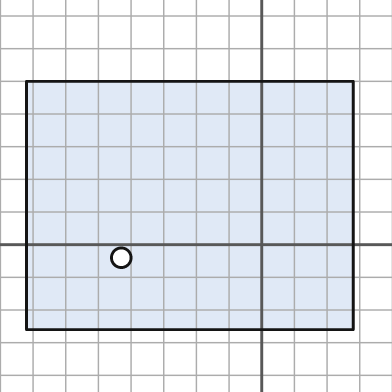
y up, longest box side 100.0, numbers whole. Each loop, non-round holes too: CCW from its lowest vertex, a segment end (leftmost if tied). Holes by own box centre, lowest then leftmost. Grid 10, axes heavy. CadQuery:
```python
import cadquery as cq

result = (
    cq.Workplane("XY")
    .moveTo(-72.0, -26.0)
    .lineTo(28.0, -26.0)
    .lineTo(28.0, 50.0)
    .lineTo(-72.0, 50.0)
    .close()
    .moveTo(-43.0, -4.0)
    .circle(3.0)
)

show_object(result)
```